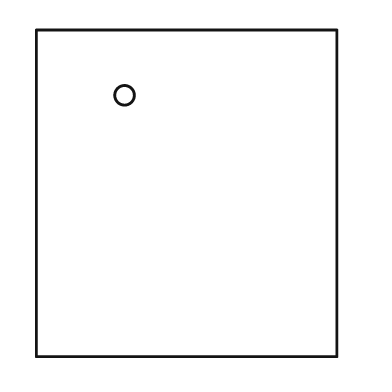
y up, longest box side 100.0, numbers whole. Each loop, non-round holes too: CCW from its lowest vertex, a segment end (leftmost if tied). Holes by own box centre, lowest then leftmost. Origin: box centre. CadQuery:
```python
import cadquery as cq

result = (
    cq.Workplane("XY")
    .moveTo(-46.0, -50.0)
    .lineTo(46.0, -50.0)
    .lineTo(46.0, 50.0)
    .lineTo(-46.0, 50.0)
    .close()
    .moveTo(-19.0, 30.0)
    .circle(3.0)
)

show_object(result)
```